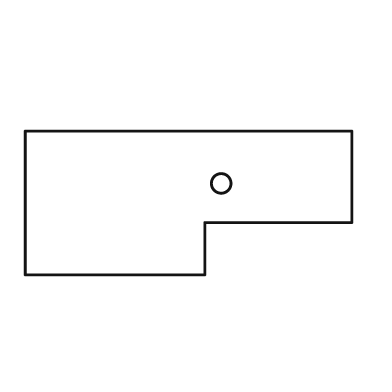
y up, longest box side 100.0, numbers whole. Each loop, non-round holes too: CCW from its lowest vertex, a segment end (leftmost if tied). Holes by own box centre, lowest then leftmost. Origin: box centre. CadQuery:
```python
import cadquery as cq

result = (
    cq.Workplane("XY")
    .moveTo(-50.0, -22.0)
    .lineTo(5.0, -22.0)
    .lineTo(5.0, -6.0)
    .lineTo(50.0, -6.0)
    .lineTo(50.0, 22.0)
    .lineTo(-50.0, 22.0)
    .close()
    .moveTo(10.0, 6.0)
    .circle(3.0)
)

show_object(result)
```